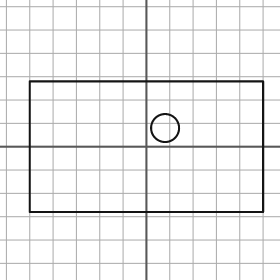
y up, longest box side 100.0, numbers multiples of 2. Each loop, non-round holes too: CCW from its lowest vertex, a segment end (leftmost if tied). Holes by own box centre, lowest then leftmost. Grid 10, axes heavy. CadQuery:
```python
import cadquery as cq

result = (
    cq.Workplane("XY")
    .moveTo(-50.0, -28.0)
    .lineTo(50.0, -28.0)
    .lineTo(50.0, 28.0)
    .lineTo(-50.0, 28.0)
    .close()
    .moveTo(8.0, 8.0)
    .circle(6.0)
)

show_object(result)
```